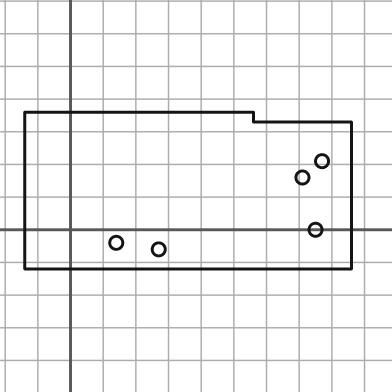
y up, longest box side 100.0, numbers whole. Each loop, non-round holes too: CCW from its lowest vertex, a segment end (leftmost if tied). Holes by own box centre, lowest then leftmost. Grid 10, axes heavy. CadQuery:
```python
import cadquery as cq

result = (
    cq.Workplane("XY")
    .moveTo(-14.0, -12.0)
    .lineTo(86.0, -12.0)
    .lineTo(86.0, 33.0)
    .lineTo(56.0, 33.0)
    .lineTo(56.0, 36.0)
    .lineTo(-14.0, 36.0)
    .close()
    .moveTo(27.0, -6.0)
    .circle(2.0)
    .moveTo(14.0, -4.0)
    .circle(2.0)
    .moveTo(75.0, 0.0)
    .circle(2.0)
    .moveTo(71.0, 16.0)
    .circle(2.0)
    .moveTo(77.0, 21.0)
    .circle(2.0)
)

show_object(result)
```